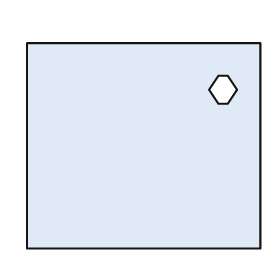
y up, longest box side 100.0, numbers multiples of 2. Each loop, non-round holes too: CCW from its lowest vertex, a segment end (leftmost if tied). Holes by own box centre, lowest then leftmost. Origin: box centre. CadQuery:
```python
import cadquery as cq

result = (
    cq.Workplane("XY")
    .moveTo(-50.0, -44.0)
    .lineTo(50.0, -44.0)
    .lineTo(50.0, 44.0)
    .lineTo(-50.0, 44.0)
    .close()
    .moveTo(32.0, 18.0)
    .lineTo(36.0, 18.0)
    .lineTo(40.0, 24.0)
    .lineTo(36.0, 30.0)
    .lineTo(32.0, 30.0)
    .lineTo(28.0, 24.0)
    .close()
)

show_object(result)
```